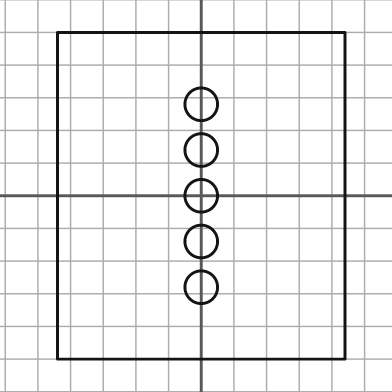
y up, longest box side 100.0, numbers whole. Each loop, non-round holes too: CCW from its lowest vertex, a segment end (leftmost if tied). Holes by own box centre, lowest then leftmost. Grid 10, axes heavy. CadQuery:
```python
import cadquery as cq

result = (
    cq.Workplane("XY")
    .moveTo(-44.0, -50.0)
    .lineTo(44.0, -50.0)
    .lineTo(44.0, 50.0)
    .lineTo(-44.0, 50.0)
    .close()
    .moveTo(0.0, -28.0)
    .circle(5.0)
    .moveTo(0.0, -14.0)
    .circle(5.0)
    .moveTo(0.0, 0.0)
    .circle(5.0)
    .moveTo(0.0, 14.0)
    .circle(5.0)
    .moveTo(0.0, 28.0)
    .circle(5.0)
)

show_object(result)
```